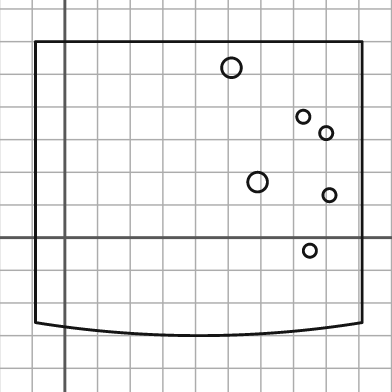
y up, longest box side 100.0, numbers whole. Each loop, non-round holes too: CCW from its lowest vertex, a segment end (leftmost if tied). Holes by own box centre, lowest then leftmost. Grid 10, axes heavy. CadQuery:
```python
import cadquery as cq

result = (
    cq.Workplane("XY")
    .moveTo(-9.0, -26.0)
    .threePointArc((41.0, -30.0), (91.0, -26.0))
    .lineTo(91.0, 60.0)
    .lineTo(-9.0, 60.0)
    .close()
    .moveTo(75.0, -4.0)
    .circle(2.0)
    .moveTo(81.0, 13.0)
    .circle(2.0)
    .moveTo(59.0, 17.0)
    .circle(3.0)
    .moveTo(80.0, 32.0)
    .circle(2.0)
    .moveTo(73.0, 37.0)
    .circle(2.0)
    .moveTo(51.0, 52.0)
    .circle(3.0)
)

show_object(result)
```